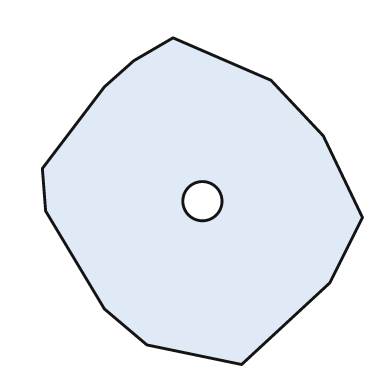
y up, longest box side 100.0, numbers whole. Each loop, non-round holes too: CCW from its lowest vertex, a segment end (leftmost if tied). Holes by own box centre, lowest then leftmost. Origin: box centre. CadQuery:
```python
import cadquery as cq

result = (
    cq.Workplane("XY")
    .moveTo(12.0, -50.0)
    .lineTo(39.0, -25.0)
    .lineTo(49.0, -5.0)
    .lineTo(37.0, 20.0)
    .lineTo(21.0, 37.0)
    .lineTo(-9.0, 50.0)
    .lineTo(-21.0, 43.0)
    .lineTo(-30.0, 35.0)
    .lineTo(-49.0, 10.0)
    .lineTo(-48.0, -3.0)
    .lineTo(-30.0, -33.0)
    .lineTo(-17.0, -44.0)
    .close()
    .moveTo(0.0, 0.0)
    .circle(6.0)
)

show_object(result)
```